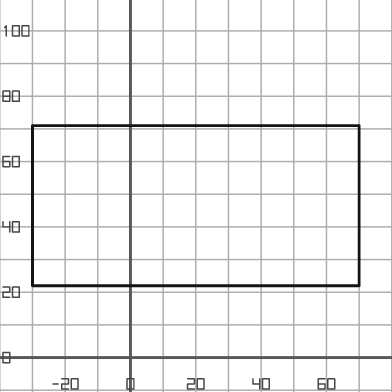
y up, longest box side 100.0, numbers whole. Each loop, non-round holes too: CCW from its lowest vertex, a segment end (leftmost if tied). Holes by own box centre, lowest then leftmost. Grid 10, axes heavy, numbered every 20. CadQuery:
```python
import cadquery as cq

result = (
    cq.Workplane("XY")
    .moveTo(-30.0, 22.0)
    .lineTo(70.0, 22.0)
    .lineTo(70.0, 71.0)
    .lineTo(-30.0, 71.0)
    .close()
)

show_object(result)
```